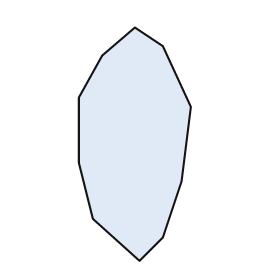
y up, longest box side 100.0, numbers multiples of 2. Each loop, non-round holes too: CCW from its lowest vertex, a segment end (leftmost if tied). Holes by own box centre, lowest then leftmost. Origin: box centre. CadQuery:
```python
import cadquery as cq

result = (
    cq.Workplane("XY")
    .moveTo(2.0, -50.0)
    .lineTo(12.0, -40.0)
    .lineTo(20.0, -16.0)
    .lineTo(24.0, 16.0)
    .lineTo(12.0, 42.0)
    .lineTo(0.0, 50.0)
    .lineTo(-14.0, 38.0)
    .lineTo(-24.0, 20.0)
    .lineTo(-24.0, -8.0)
    .lineTo(-18.0, -32.0)
    .close()
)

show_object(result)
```